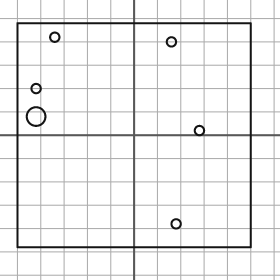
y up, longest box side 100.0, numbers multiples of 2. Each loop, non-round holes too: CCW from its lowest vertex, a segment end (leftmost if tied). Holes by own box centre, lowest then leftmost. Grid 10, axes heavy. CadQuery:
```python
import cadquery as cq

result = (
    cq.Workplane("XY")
    .moveTo(-50.0, -48.0)
    .lineTo(50.0, -48.0)
    .lineTo(50.0, 48.0)
    .lineTo(-50.0, 48.0)
    .close()
    .moveTo(18.0, -38.0)
    .circle(2.0)
    .moveTo(28.0, 2.0)
    .circle(2.0)
    .moveTo(-42.0, 8.0)
    .circle(4.0)
    .moveTo(-42.0, 20.0)
    .circle(2.0)
    .moveTo(16.0, 40.0)
    .circle(2.0)
    .moveTo(-34.0, 42.0)
    .circle(2.0)
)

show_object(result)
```